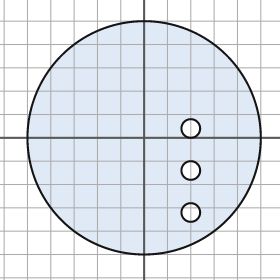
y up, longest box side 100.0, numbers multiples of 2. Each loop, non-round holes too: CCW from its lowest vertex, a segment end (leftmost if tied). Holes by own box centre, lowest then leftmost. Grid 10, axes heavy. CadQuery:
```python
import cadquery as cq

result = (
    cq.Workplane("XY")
    .moveTo(0.0, 0.0)
    .circle(50.0)
    .moveTo(20.0, -32.0)
    .circle(4.0)
    .moveTo(20.0, -14.0)
    .circle(4.0)
    .moveTo(20.0, 4.0)
    .circle(4.0)
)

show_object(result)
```